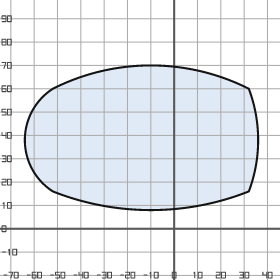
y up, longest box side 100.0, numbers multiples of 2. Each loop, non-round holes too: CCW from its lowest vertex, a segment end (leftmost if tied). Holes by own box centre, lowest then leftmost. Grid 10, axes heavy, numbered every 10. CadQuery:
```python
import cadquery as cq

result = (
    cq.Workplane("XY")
    .moveTo(-52.0, 16.0)
    .threePointArc((-10.0, 8.0), (32.0, 16.0))
    .threePointArc((36.0, 38.0), (32.0, 60.0))
    .threePointArc((-10.0, 70.0), (-52.0, 60.0))
    .threePointArc((-64.0, 38.0), (-52.0, 16.0))
    .close()
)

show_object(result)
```